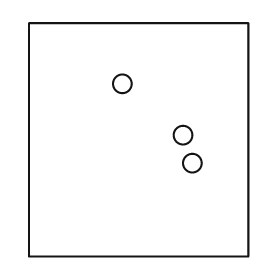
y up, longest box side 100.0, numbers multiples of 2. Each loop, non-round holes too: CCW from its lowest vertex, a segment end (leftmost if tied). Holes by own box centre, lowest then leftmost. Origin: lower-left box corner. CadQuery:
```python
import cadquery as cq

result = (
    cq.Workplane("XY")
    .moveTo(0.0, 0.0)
    .lineTo(94.0, 0.0)
    .lineTo(94.0, 100.0)
    .lineTo(0.0, 100.0)
    .close()
    .moveTo(70.0, 40.0)
    .circle(4.0)
    .moveTo(66.0, 52.0)
    .circle(4.0)
    .moveTo(40.0, 74.0)
    .circle(4.0)
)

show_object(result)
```